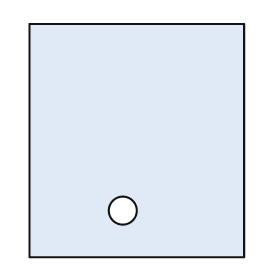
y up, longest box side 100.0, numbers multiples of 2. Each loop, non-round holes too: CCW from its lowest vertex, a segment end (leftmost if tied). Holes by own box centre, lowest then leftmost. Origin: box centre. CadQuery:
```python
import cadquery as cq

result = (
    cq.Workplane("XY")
    .moveTo(-46.0, -50.0)
    .lineTo(46.0, -50.0)
    .lineTo(46.0, 50.0)
    .lineTo(-46.0, 50.0)
    .close()
    .moveTo(-6.0, -30.0)
    .circle(6.0)
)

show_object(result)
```